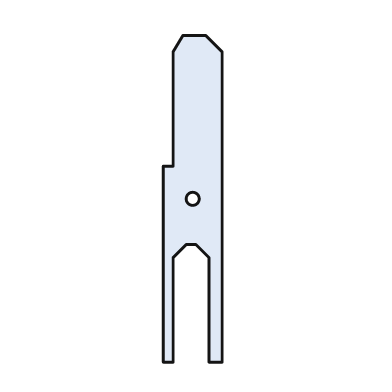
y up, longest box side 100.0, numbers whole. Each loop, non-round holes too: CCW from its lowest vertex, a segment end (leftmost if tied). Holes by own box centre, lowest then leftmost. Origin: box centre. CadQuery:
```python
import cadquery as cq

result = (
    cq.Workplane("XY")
    .moveTo(-9.0, -50.0)
    .lineTo(-6.0, -50.0)
    .lineTo(-6.0, -18.0)
    .lineTo(-2.0, -14.0)
    .lineTo(1.0, -14.0)
    .lineTo(5.0, -18.0)
    .lineTo(5.0, -50.0)
    .lineTo(9.0, -50.0)
    .lineTo(9.0, 45.0)
    .lineTo(4.0, 50.0)
    .lineTo(-3.0, 50.0)
    .lineTo(-6.0, 45.0)
    .lineTo(-6.0, 10.0)
    .lineTo(-9.0, 10.0)
    .close()
    .moveTo(0.0, 0.0)
    .circle(2.0)
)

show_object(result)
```